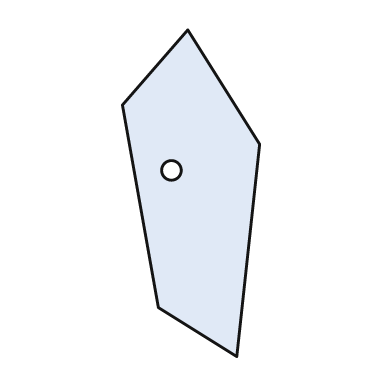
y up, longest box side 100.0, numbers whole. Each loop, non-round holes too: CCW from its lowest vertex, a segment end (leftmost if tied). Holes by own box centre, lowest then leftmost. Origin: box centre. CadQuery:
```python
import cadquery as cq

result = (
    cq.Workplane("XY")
    .moveTo(14.0, -50.0)
    .lineTo(21.0, 15.0)
    .lineTo(-1.0, 50.0)
    .lineTo(-21.0, 27.0)
    .lineTo(-10.0, -35.0)
    .close()
    .moveTo(-6.0, 7.0)
    .circle(3.0)
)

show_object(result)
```